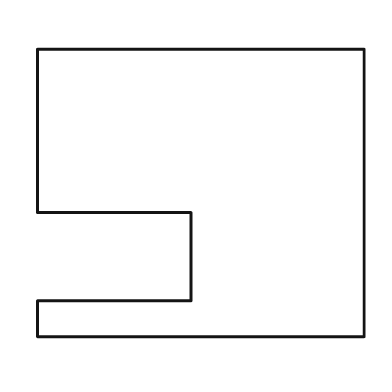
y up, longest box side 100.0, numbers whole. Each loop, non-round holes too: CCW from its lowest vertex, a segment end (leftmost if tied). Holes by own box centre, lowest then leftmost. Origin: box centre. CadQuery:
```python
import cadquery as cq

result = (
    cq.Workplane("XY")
    .moveTo(-50.0, -44.0)
    .lineTo(50.0, -44.0)
    .lineTo(50.0, 44.0)
    .lineTo(-50.0, 44.0)
    .lineTo(-50.0, -6.0)
    .lineTo(-3.0, -6.0)
    .lineTo(-3.0, -33.0)
    .lineTo(-50.0, -33.0)
    .close()
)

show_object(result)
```